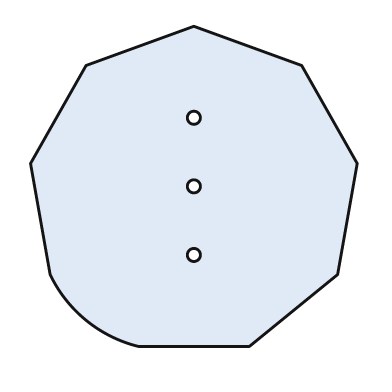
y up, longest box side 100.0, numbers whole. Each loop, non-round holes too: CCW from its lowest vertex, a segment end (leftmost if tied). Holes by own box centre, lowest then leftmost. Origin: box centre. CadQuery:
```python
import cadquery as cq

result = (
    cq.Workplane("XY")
    .moveTo(-17.0, -49.0)
    .lineTo(17.0, -49.0)
    .lineTo(44.0, -27.0)
    .lineTo(50.0, 7.0)
    .lineTo(33.0, 37.0)
    .lineTo(0.0, 49.0)
    .lineTo(-33.0, 37.0)
    .lineTo(-50.0, 7.0)
    .lineTo(-44.0, -27.0)
    .threePointArc((-33.0, -41.0), (-17.0, -49.0))
    .close()
    .moveTo(0.0, -21.0)
    .circle(2.0)
    .moveTo(0.0, 0.0)
    .circle(2.0)
    .moveTo(0.0, 21.0)
    .circle(2.0)
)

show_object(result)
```